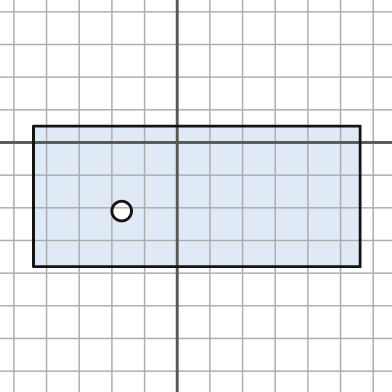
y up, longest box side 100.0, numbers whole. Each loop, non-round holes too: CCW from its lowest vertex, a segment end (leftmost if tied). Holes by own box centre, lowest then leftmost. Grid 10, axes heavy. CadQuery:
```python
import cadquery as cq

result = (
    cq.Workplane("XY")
    .moveTo(-44.0, -38.0)
    .lineTo(56.0, -38.0)
    .lineTo(56.0, 5.0)
    .lineTo(-44.0, 5.0)
    .close()
    .moveTo(-17.0, -21.0)
    .circle(3.0)
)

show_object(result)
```